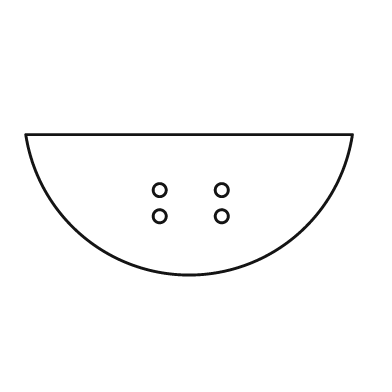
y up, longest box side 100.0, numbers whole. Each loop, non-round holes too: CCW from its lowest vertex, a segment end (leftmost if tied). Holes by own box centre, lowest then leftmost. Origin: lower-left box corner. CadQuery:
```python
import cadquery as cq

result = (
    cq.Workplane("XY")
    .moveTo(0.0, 43.0)
    .threePointArc((50.0, 0.0), (100.0, 43.0))
    .close()
    .moveTo(41.0, 18.0)
    .circle(2.0)
    .moveTo(60.0, 18.0)
    .circle(2.0)
    .moveTo(41.0, 26.0)
    .circle(2.0)
    .moveTo(60.0, 26.0)
    .circle(2.0)
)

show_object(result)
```